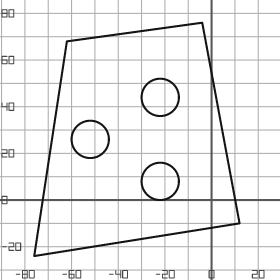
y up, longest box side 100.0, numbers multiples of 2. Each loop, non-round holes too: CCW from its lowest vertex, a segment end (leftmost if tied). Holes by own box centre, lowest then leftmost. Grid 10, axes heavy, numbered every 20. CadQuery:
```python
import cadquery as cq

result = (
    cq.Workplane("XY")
    .moveTo(-76.0, -24.0)
    .lineTo(12.0, -10.0)
    .lineTo(-4.0, 76.0)
    .lineTo(-62.0, 68.0)
    .close()
    .moveTo(-22.0, 8.0)
    .circle(8.0)
    .moveTo(-52.0, 26.0)
    .circle(8.0)
    .moveTo(-22.0, 44.0)
    .circle(8.0)
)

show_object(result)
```